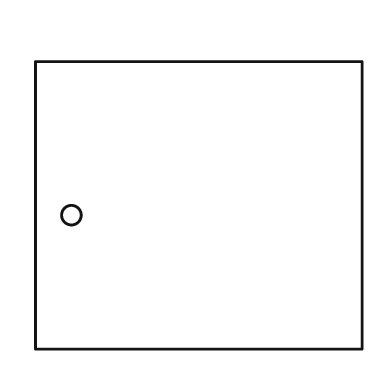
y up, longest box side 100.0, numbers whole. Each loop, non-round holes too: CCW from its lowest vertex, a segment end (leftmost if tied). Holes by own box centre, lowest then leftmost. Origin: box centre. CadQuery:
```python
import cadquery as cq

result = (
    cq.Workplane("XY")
    .moveTo(-50.0, -44.0)
    .lineTo(50.0, -44.0)
    .lineTo(50.0, 44.0)
    .lineTo(-50.0, 44.0)
    .close()
    .moveTo(-39.0, -3.0)
    .circle(3.0)
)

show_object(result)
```